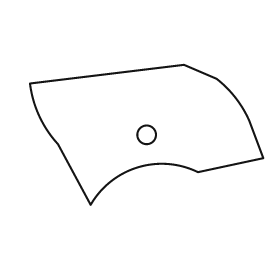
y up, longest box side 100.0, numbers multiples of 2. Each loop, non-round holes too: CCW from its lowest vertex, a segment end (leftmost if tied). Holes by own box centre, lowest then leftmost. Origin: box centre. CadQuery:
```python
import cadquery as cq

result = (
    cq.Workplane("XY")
    .moveTo(-24.0, -30.0)
    .threePointArc((-4.0, -14.0), (22.0, -16.0))
    .lineTo(50.0, -10.0)
    .lineTo(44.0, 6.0)
    .threePointArc((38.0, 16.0), (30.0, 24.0))
    .lineTo(16.0, 30.0)
    .lineTo(-50.0, 22.0)
    .threePointArc((-46.0, 8.0), (-38.0, -4.0))
    .close()
    .moveTo(0.0, 0.0)
    .circle(4.0)
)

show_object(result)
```